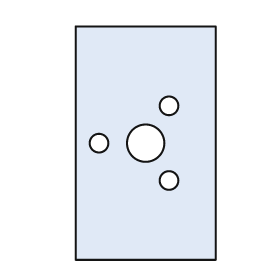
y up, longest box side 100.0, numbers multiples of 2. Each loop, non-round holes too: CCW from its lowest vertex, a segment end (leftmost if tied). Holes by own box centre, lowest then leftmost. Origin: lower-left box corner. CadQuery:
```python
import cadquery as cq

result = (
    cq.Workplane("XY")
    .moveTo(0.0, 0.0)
    .lineTo(60.0, 0.0)
    .lineTo(60.0, 100.0)
    .lineTo(0.0, 100.0)
    .close()
    .moveTo(40.0, 34.0)
    .circle(4.0)
    .moveTo(10.0, 50.0)
    .circle(4.0)
    .moveTo(30.0, 50.0)
    .circle(8.0)
    .moveTo(40.0, 66.0)
    .circle(4.0)
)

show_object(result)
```